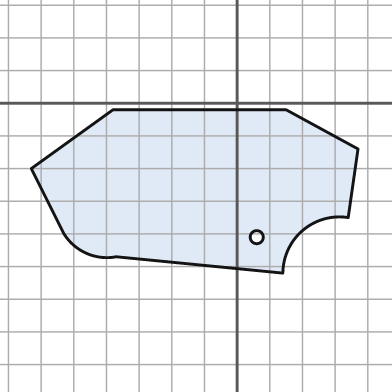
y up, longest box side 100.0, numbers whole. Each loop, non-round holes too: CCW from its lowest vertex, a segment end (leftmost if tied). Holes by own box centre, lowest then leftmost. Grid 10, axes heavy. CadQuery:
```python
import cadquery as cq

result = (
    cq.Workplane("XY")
    .moveTo(14.0, -52.0)
    .threePointArc((20.0, -39.0), (34.0, -35.0))
    .lineTo(37.0, -14.0)
    .lineTo(15.0, -2.0)
    .lineTo(-38.0, -2.0)
    .lineTo(-63.0, -20.0)
    .lineTo(-53.0, -40.0)
    .threePointArc((-46.0, -46.0), (-37.0, -47.0))
    .close()
    .moveTo(6.0, -41.0)
    .circle(2.0)
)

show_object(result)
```